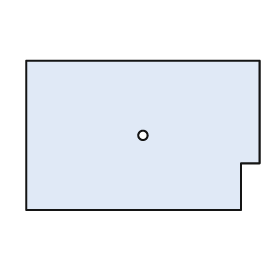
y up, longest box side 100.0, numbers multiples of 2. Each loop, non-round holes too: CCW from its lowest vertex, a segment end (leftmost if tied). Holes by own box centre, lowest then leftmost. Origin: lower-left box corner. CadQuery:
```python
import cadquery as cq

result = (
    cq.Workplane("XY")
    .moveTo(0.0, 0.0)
    .lineTo(92.0, 0.0)
    .lineTo(92.0, 20.0)
    .lineTo(100.0, 20.0)
    .lineTo(100.0, 64.0)
    .lineTo(0.0, 64.0)
    .close()
    .moveTo(50.0, 32.0)
    .circle(2.0)
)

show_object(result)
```